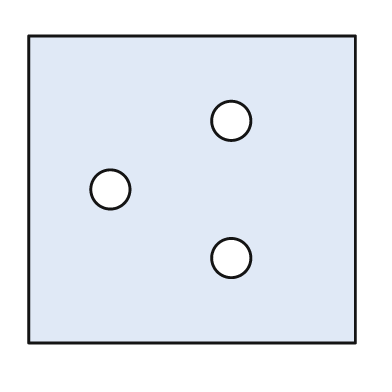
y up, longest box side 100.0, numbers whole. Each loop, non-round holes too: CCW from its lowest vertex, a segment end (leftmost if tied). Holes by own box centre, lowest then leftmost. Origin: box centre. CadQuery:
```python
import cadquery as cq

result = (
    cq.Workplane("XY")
    .moveTo(-50.0, -47.0)
    .lineTo(50.0, -47.0)
    .lineTo(50.0, 47.0)
    .lineTo(-50.0, 47.0)
    .close()
    .moveTo(12.0, -21.0)
    .circle(6.0)
    .moveTo(-25.0, 0.0)
    .circle(6.0)
    .moveTo(12.0, 21.0)
    .circle(6.0)
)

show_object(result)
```